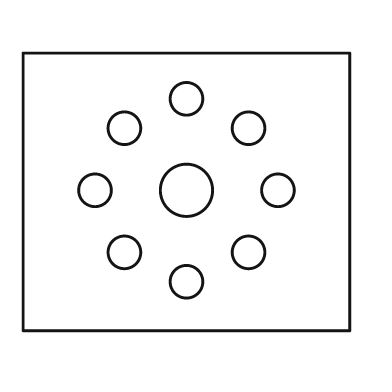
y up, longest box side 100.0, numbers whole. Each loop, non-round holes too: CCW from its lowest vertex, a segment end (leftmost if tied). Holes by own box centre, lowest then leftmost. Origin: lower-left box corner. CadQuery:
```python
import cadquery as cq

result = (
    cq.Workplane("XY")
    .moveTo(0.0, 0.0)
    .lineTo(100.0, 0.0)
    .lineTo(100.0, 85.0)
    .lineTo(0.0, 85.0)
    .close()
    .moveTo(50.0, 15.0)
    .circle(5.0)
    .moveTo(31.0, 24.0)
    .circle(5.0)
    .moveTo(69.0, 24.0)
    .circle(5.0)
    .moveTo(22.0, 43.0)
    .circle(5.0)
    .moveTo(50.0, 43.0)
    .circle(8.0)
    .moveTo(78.0, 43.0)
    .circle(5.0)
    .moveTo(31.0, 62.0)
    .circle(5.0)
    .moveTo(69.0, 62.0)
    .circle(5.0)
    .moveTo(50.0, 71.0)
    .circle(5.0)
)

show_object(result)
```